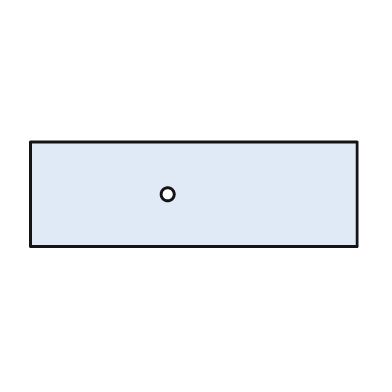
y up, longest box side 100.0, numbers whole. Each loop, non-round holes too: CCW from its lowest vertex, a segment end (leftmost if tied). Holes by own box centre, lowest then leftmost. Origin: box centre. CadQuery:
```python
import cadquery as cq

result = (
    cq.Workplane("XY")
    .moveTo(-50.0, -16.0)
    .lineTo(50.0, -16.0)
    .lineTo(50.0, 16.0)
    .lineTo(-50.0, 16.0)
    .close()
    .moveTo(-8.0, 0.0)
    .circle(2.0)
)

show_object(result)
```